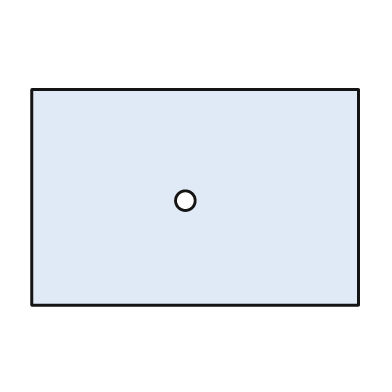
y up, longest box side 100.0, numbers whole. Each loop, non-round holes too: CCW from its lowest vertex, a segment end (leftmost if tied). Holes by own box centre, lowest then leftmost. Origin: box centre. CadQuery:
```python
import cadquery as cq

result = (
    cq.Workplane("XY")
    .moveTo(-50.0, -33.0)
    .lineTo(50.0, -33.0)
    .lineTo(50.0, 33.0)
    .lineTo(-50.0, 33.0)
    .close()
    .moveTo(-3.0, -1.0)
    .circle(3.0)
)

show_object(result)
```